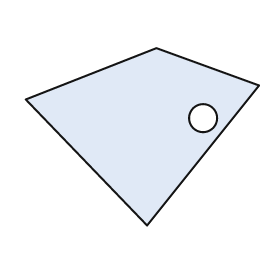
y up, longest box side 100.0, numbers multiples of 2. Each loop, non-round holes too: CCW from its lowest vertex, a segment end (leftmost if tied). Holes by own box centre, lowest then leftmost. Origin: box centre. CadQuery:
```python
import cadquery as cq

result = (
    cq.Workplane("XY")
    .moveTo(2.0, -38.0)
    .lineTo(50.0, 22.0)
    .lineTo(6.0, 38.0)
    .lineTo(-50.0, 16.0)
    .close()
    .moveTo(26.0, 8.0)
    .circle(6.0)
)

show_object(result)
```